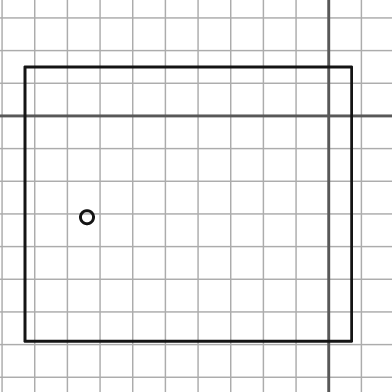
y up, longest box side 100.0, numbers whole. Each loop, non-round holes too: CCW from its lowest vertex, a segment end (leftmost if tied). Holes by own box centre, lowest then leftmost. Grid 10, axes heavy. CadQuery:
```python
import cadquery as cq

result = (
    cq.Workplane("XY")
    .moveTo(-93.0, -69.0)
    .lineTo(7.0, -69.0)
    .lineTo(7.0, 15.0)
    .lineTo(-93.0, 15.0)
    .close()
    .moveTo(-74.0, -31.0)
    .circle(2.0)
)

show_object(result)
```